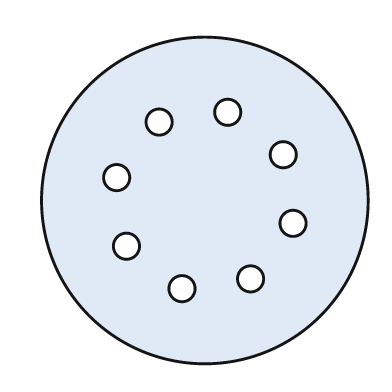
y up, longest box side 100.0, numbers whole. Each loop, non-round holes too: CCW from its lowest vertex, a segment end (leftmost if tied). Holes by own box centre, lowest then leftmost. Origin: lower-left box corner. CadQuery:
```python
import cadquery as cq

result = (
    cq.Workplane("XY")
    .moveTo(50.0, 50.0)
    .circle(50.0)
    .moveTo(43.0, 23.0)
    .circle(4.0)
    .moveTo(64.0, 26.0)
    .circle(4.0)
    .moveTo(26.0, 36.0)
    .circle(4.0)
    .moveTo(77.0, 43.0)
    .circle(4.0)
    .moveTo(23.0, 57.0)
    .circle(4.0)
    .moveTo(74.0, 64.0)
    .circle(4.0)
    .moveTo(36.0, 74.0)
    .circle(4.0)
    .moveTo(57.0, 77.0)
    .circle(4.0)
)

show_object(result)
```